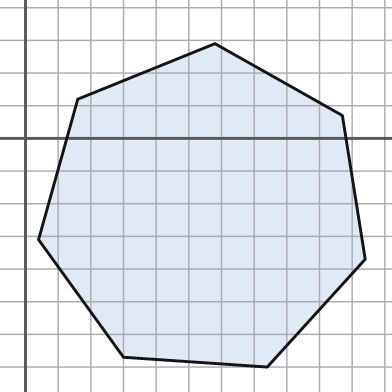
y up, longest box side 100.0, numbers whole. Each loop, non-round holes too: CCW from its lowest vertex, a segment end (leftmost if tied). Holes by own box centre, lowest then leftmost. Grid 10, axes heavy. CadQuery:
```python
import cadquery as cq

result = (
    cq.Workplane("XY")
    .moveTo(74.0, -70.0)
    .lineTo(104.0, -37.0)
    .lineTo(97.0, 7.0)
    .lineTo(58.0, 29.0)
    .lineTo(16.0, 12.0)
    .lineTo(4.0, -31.0)
    .lineTo(30.0, -67.0)
    .close()
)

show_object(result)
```